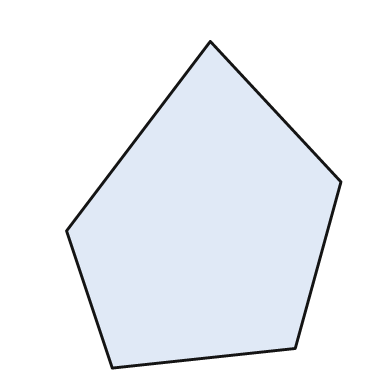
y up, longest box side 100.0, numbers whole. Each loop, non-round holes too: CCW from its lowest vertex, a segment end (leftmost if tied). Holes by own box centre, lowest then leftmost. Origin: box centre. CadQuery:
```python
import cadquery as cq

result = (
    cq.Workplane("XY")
    .moveTo(-28.0, -50.0)
    .lineTo(28.0, -44.0)
    .lineTo(42.0, 7.0)
    .lineTo(2.0, 50.0)
    .lineTo(-42.0, -8.0)
    .close()
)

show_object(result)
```